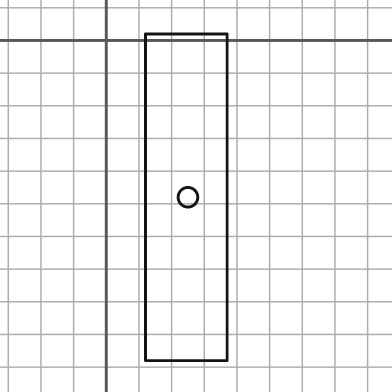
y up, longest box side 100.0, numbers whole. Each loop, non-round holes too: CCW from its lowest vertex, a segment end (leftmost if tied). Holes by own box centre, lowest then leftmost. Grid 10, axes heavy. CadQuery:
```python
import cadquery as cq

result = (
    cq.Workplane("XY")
    .moveTo(12.0, -98.0)
    .lineTo(37.0, -98.0)
    .lineTo(37.0, 2.0)
    .lineTo(12.0, 2.0)
    .close()
    .moveTo(25.0, -48.0)
    .circle(3.0)
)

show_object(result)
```